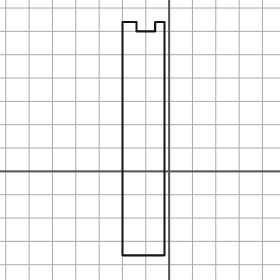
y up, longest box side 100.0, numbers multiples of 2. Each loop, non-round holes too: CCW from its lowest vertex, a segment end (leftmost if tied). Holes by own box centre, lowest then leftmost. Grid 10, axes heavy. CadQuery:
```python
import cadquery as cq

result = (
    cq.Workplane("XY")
    .moveTo(-20.0, -36.0)
    .lineTo(-2.0, -36.0)
    .lineTo(-2.0, 64.0)
    .lineTo(-6.0, 64.0)
    .lineTo(-6.0, 60.0)
    .lineTo(-14.0, 60.0)
    .lineTo(-14.0, 64.0)
    .lineTo(-20.0, 64.0)
    .close()
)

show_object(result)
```